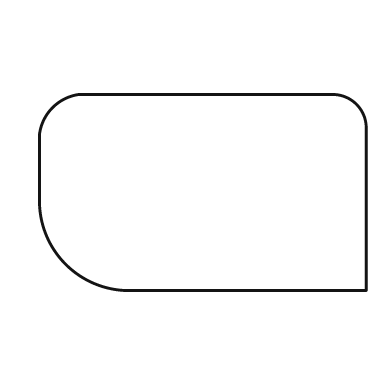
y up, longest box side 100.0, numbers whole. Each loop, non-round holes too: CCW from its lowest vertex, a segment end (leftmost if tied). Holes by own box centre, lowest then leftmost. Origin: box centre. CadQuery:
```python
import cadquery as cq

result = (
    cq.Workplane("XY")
    .moveTo(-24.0, -30.0)
    .lineTo(50.0, -30.0)
    .lineTo(50.0, 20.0)
    .threePointArc((47.0, 27.0), (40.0, 30.0))
    .lineTo(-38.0, 30.0)
    .threePointArc((-46.0, 26.0), (-50.0, 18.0))
    .lineTo(-50.0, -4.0)
    .threePointArc((-42.0, -22.0), (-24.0, -30.0))
    .close()
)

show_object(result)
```